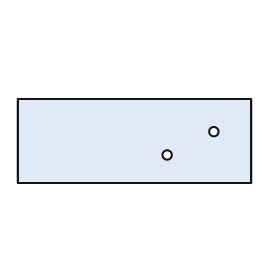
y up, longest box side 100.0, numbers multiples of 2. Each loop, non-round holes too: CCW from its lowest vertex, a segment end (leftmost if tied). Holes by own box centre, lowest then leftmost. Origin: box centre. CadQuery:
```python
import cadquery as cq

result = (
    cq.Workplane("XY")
    .moveTo(-50.0, -18.0)
    .lineTo(50.0, -18.0)
    .lineTo(50.0, 18.0)
    .lineTo(-50.0, 18.0)
    .close()
    .moveTo(14.0, -6.0)
    .circle(2.0)
    .moveTo(34.0, 4.0)
    .circle(2.0)
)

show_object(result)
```